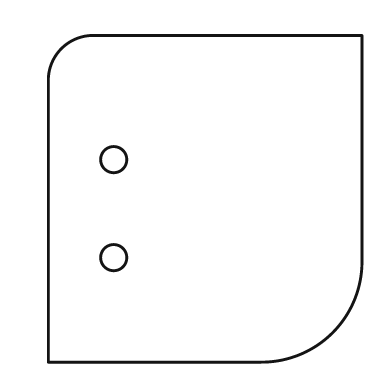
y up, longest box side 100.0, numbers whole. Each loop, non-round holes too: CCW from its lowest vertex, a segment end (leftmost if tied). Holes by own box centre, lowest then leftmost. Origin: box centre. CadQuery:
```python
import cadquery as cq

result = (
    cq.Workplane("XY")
    .moveTo(-48.0, -50.0)
    .lineTo(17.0, -50.0)
    .threePointArc((39.0, -41.0), (48.0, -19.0))
    .lineTo(48.0, 50.0)
    .lineTo(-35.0, 50.0)
    .threePointArc((-44.0, 46.0), (-48.0, 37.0))
    .close()
    .moveTo(-28.0, -18.0)
    .circle(4.0)
    .moveTo(-28.0, 12.0)
    .circle(4.0)
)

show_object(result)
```